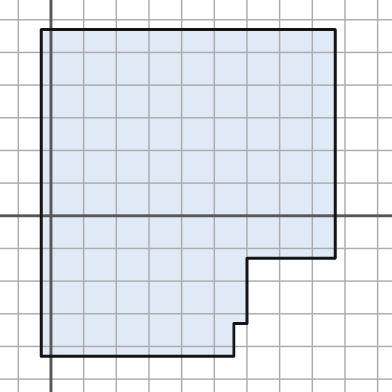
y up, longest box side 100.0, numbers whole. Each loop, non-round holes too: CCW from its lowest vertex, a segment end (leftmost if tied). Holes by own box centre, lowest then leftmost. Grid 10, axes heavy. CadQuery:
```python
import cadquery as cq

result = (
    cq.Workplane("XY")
    .moveTo(-3.0, -43.0)
    .lineTo(56.0, -43.0)
    .lineTo(56.0, -33.0)
    .lineTo(60.0, -33.0)
    .lineTo(60.0, -13.0)
    .lineTo(87.0, -13.0)
    .lineTo(87.0, 57.0)
    .lineTo(-3.0, 57.0)
    .close()
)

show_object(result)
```